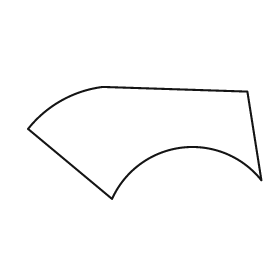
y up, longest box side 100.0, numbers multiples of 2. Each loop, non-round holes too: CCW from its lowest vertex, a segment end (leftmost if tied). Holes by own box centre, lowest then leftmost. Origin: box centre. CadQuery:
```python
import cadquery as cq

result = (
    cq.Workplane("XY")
    .moveTo(-14.0, -24.0)
    .threePointArc((16.0, -2.0), (50.0, -16.0))
    .lineTo(44.0, 22.0)
    .lineTo(-18.0, 24.0)
    .threePointArc((-36.0, 18.0), (-50.0, 6.0))
    .close()
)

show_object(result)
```